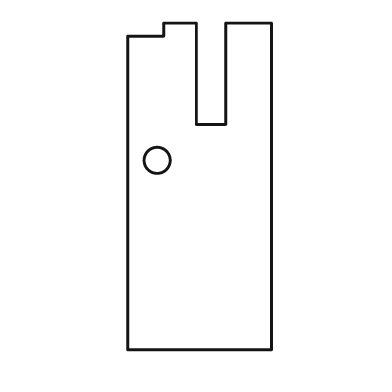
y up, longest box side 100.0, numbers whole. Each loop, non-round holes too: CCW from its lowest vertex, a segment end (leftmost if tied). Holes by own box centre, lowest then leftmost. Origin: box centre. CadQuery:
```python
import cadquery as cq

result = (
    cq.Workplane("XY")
    .moveTo(-22.0, -50.0)
    .lineTo(22.0, -50.0)
    .lineTo(22.0, 50.0)
    .lineTo(8.0, 50.0)
    .lineTo(8.0, 19.0)
    .lineTo(-1.0, 19.0)
    .lineTo(-1.0, 50.0)
    .lineTo(-11.0, 50.0)
    .lineTo(-11.0, 46.0)
    .lineTo(-22.0, 46.0)
    .close()
    .moveTo(-13.0, 8.0)
    .circle(4.0)
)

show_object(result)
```